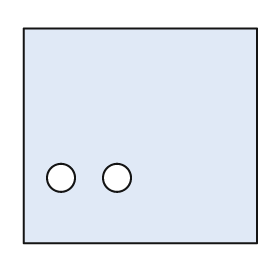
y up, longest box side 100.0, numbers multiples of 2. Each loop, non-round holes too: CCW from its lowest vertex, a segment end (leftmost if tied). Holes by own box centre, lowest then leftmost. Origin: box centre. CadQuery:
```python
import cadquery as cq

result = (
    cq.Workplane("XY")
    .moveTo(-50.0, -46.0)
    .lineTo(50.0, -46.0)
    .lineTo(50.0, 46.0)
    .lineTo(-50.0, 46.0)
    .close()
    .moveTo(-34.0, -18.0)
    .circle(6.0)
    .moveTo(-10.0, -18.0)
    .circle(6.0)
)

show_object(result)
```